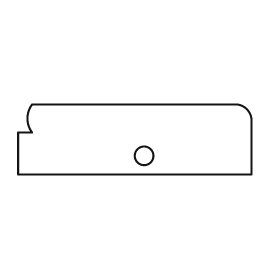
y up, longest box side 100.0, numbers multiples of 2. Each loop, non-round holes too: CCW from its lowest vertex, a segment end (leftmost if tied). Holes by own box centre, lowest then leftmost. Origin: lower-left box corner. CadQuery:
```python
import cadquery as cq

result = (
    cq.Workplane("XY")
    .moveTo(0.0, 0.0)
    .lineTo(100.0, 0.0)
    .lineTo(100.0, 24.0)
    .threePointArc((98.0, 28.0), (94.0, 30.0))
    .lineTo(6.0, 30.0)
    .threePointArc((4.0, 24.0), (6.0, 18.0))
    .lineTo(0.0, 18.0)
    .close()
    .moveTo(54.0, 8.0)
    .circle(4.0)
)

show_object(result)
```